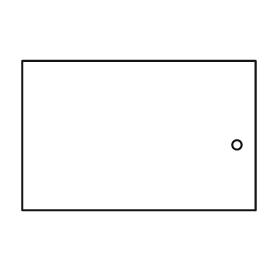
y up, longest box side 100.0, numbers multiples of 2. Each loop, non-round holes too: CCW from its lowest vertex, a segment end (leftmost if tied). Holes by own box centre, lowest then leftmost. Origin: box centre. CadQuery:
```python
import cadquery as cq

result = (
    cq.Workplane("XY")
    .moveTo(-50.0, -32.0)
    .lineTo(50.0, -32.0)
    .lineTo(50.0, 32.0)
    .lineTo(-50.0, 32.0)
    .close()
    .moveTo(42.0, -4.0)
    .circle(2.0)
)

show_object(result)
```